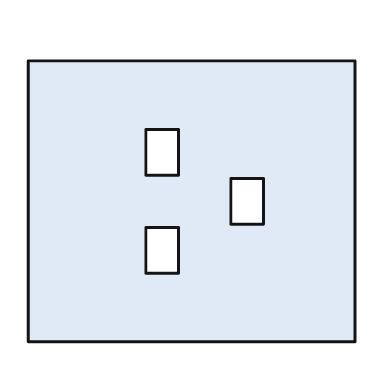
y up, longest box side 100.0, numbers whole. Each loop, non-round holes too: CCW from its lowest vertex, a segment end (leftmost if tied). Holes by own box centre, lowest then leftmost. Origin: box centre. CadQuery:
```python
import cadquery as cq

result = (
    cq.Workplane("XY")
    .moveTo(-50.0, -43.0)
    .lineTo(50.0, -43.0)
    .lineTo(50.0, 43.0)
    .lineTo(-50.0, 43.0)
    .close()
    .moveTo(-14.0, -22.0)
    .lineTo(-4.0, -22.0)
    .lineTo(-4.0, -8.0)
    .lineTo(-14.0, -8.0)
    .close()
    .moveTo(12.0, -7.0)
    .lineTo(22.0, -7.0)
    .lineTo(22.0, 7.0)
    .lineTo(12.0, 7.0)
    .close()
    .moveTo(-14.0, 8.0)
    .lineTo(-4.0, 8.0)
    .lineTo(-4.0, 22.0)
    .lineTo(-14.0, 22.0)
    .close()
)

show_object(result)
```